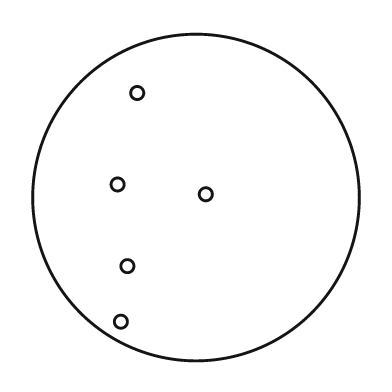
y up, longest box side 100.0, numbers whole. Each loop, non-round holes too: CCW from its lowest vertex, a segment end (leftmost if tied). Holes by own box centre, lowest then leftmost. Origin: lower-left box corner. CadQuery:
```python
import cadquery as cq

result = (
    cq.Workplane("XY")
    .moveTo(50.0, 50.0)
    .circle(50.0)
    .moveTo(27.0, 12.0)
    .circle(2.0)
    .moveTo(29.0, 29.0)
    .circle(2.0)
    .moveTo(53.0, 51.0)
    .circle(2.0)
    .moveTo(26.0, 54.0)
    .circle(2.0)
    .moveTo(32.0, 82.0)
    .circle(2.0)
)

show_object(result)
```